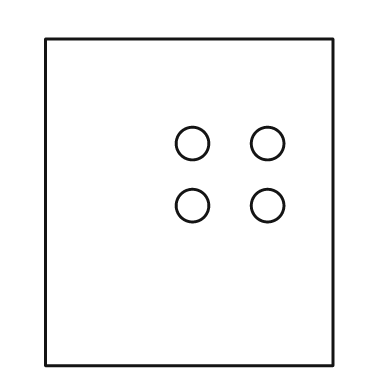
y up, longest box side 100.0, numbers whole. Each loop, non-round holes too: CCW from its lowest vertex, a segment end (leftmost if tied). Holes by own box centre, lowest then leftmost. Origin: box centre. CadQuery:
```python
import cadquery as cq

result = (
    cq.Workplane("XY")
    .moveTo(-44.0, -50.0)
    .lineTo(44.0, -50.0)
    .lineTo(44.0, 50.0)
    .lineTo(-44.0, 50.0)
    .close()
    .moveTo(1.0, -1.0)
    .circle(5.0)
    .moveTo(24.0, -1.0)
    .circle(5.0)
    .moveTo(1.0, 18.0)
    .circle(5.0)
    .moveTo(24.0, 18.0)
    .circle(5.0)
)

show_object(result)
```